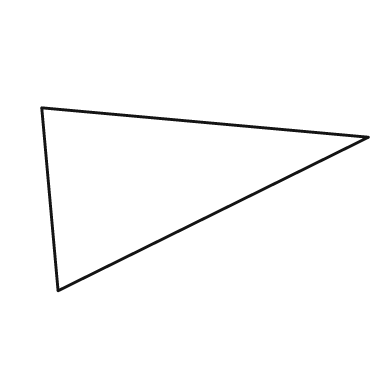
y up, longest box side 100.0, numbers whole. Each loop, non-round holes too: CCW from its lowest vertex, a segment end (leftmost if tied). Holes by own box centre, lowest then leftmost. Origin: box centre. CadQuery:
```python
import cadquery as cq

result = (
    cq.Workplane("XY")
    .moveTo(-45.0, -28.0)
    .lineTo(50.0, 19.0)
    .lineTo(-50.0, 28.0)
    .close()
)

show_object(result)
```